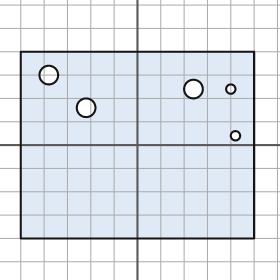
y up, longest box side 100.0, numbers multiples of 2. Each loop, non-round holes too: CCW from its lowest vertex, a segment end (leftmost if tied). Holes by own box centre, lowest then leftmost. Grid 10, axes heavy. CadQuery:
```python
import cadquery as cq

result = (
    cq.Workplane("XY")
    .moveTo(-50.0, -40.0)
    .lineTo(50.0, -40.0)
    .lineTo(50.0, 40.0)
    .lineTo(-50.0, 40.0)
    .close()
    .moveTo(42.0, 4.0)
    .circle(2.0)
    .moveTo(-22.0, 16.0)
    .circle(4.0)
    .moveTo(24.0, 24.0)
    .circle(4.0)
    .moveTo(40.0, 24.0)
    .circle(2.0)
    .moveTo(-38.0, 30.0)
    .circle(4.0)
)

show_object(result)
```